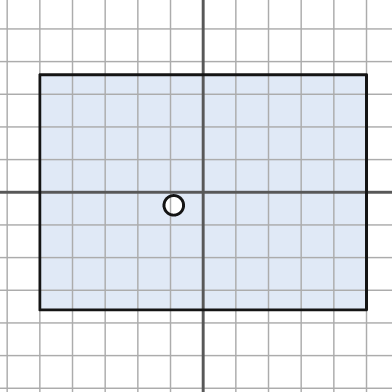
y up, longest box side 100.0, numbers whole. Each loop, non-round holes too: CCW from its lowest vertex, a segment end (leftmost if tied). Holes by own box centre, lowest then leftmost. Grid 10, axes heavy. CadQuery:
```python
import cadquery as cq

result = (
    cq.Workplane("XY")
    .moveTo(-50.0, -36.0)
    .lineTo(50.0, -36.0)
    .lineTo(50.0, 36.0)
    .lineTo(-50.0, 36.0)
    .close()
    .moveTo(-9.0, -4.0)
    .circle(3.0)
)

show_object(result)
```